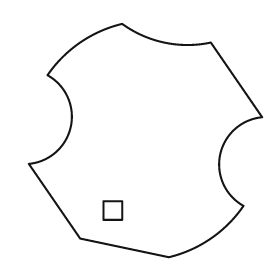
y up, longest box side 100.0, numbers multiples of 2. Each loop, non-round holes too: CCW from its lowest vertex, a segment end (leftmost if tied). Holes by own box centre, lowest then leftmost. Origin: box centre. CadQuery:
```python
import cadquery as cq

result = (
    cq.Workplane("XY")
    .moveTo(10.0, -50.0)
    .threePointArc((28.0, -42.0), (42.0, -28.0))
    .threePointArc((32.0, -6.0), (50.0, 10.0))
    .lineTo(28.0, 42.0)
    .threePointArc((8.0, 42.0), (-10.0, 50.0))
    .threePointArc((-28.0, 42.0), (-42.0, 28.0))
    .threePointArc((-32.0, 6.0), (-50.0, -10.0))
    .lineTo(-28.0, -42.0)
    .close()
    .moveTo(-18.0, -34.0)
    .lineTo(-10.0, -34.0)
    .lineTo(-10.0, -26.0)
    .lineTo(-18.0, -26.0)
    .close()
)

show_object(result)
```